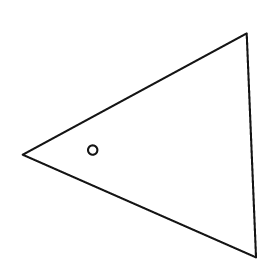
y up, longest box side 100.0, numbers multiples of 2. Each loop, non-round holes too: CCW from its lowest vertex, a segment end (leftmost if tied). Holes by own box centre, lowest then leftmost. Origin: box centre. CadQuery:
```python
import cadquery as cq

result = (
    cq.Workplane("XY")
    .moveTo(50.0, -48.0)
    .lineTo(46.0, 48.0)
    .lineTo(-50.0, -4.0)
    .close()
    .moveTo(-20.0, -2.0)
    .circle(2.0)
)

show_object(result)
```